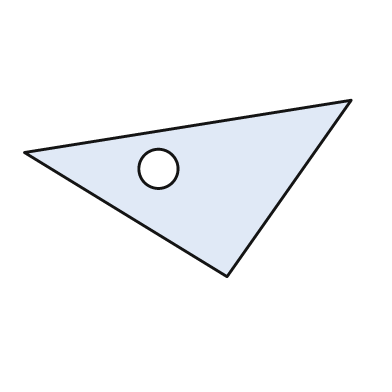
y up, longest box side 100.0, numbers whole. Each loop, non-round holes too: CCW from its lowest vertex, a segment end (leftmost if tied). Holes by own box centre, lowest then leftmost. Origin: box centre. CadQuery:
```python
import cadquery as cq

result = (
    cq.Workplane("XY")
    .moveTo(12.0, -27.0)
    .lineTo(50.0, 27.0)
    .lineTo(-50.0, 11.0)
    .close()
    .moveTo(-9.0, 6.0)
    .circle(6.0)
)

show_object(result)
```